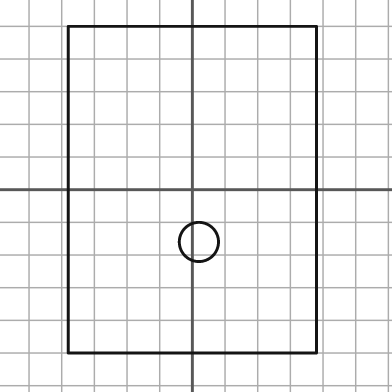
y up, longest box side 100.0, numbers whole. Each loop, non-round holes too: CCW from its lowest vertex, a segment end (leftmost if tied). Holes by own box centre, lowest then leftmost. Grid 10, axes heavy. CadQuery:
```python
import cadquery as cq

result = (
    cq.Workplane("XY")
    .moveTo(-38.0, -50.0)
    .lineTo(38.0, -50.0)
    .lineTo(38.0, 50.0)
    .lineTo(-38.0, 50.0)
    .close()
    .moveTo(2.0, -16.0)
    .circle(6.0)
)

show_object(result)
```